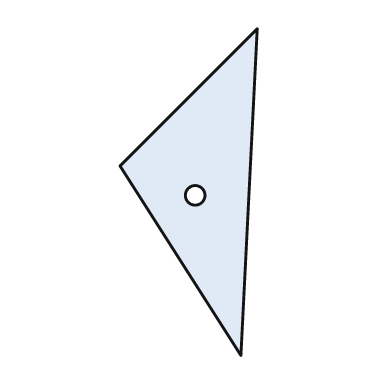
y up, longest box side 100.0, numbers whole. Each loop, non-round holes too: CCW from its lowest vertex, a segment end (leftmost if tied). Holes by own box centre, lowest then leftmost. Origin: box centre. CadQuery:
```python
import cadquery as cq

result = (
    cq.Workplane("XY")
    .moveTo(16.0, -50.0)
    .lineTo(21.0, 50.0)
    .lineTo(-21.0, 8.0)
    .close()
    .moveTo(2.0, -1.0)
    .circle(3.0)
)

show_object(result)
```